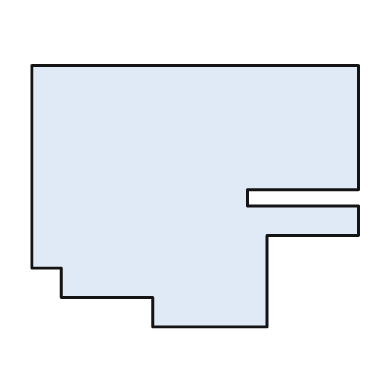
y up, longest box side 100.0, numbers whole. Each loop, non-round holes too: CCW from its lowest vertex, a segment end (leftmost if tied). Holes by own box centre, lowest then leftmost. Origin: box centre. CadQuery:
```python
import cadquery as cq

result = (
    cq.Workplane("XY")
    .moveTo(-13.0, -40.0)
    .lineTo(22.0, -40.0)
    .lineTo(22.0, -12.0)
    .lineTo(50.0, -12.0)
    .lineTo(50.0, -3.0)
    .lineTo(16.0, -3.0)
    .lineTo(16.0, 2.0)
    .lineTo(50.0, 2.0)
    .lineTo(50.0, 40.0)
    .lineTo(-50.0, 40.0)
    .lineTo(-50.0, -22.0)
    .lineTo(-41.0, -22.0)
    .lineTo(-41.0, -31.0)
    .lineTo(-13.0, -31.0)
    .close()
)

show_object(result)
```